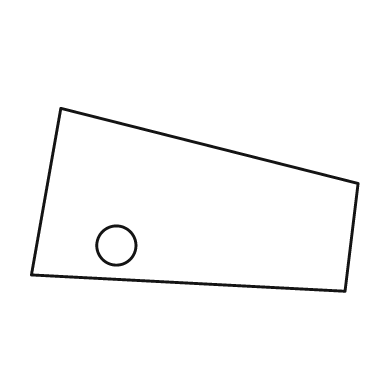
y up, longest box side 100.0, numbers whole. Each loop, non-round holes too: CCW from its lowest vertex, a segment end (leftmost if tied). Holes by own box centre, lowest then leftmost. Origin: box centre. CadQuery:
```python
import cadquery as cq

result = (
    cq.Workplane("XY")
    .moveTo(46.0, -28.0)
    .lineTo(50.0, 5.0)
    .lineTo(-41.0, 28.0)
    .lineTo(-50.0, -23.0)
    .close()
    .moveTo(-24.0, -14.0)
    .circle(6.0)
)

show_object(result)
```